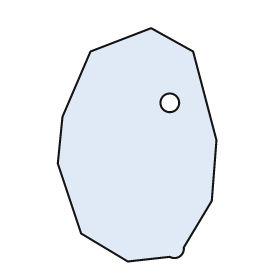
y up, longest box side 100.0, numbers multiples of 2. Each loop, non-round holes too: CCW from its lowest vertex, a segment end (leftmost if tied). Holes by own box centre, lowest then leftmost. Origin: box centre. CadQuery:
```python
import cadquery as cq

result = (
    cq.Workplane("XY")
    .moveTo(-4.0, -50.0)
    .lineTo(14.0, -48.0)
    .threePointArc((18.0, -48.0), (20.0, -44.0))
    .lineTo(32.0, -24.0)
    .lineTo(34.0, 2.0)
    .lineTo(24.0, 40.0)
    .lineTo(6.0, 50.0)
    .lineTo(-20.0, 40.0)
    .lineTo(-32.0, 12.0)
    .lineTo(-34.0, -8.0)
    .lineTo(-24.0, -38.0)
    .close()
    .moveTo(14.0, 18.0)
    .circle(4.0)
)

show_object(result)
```